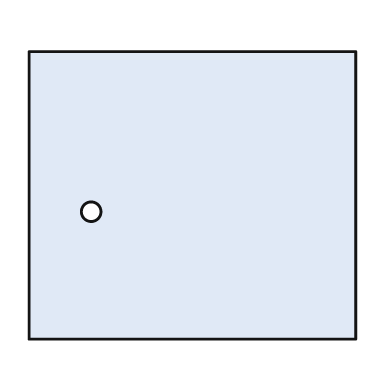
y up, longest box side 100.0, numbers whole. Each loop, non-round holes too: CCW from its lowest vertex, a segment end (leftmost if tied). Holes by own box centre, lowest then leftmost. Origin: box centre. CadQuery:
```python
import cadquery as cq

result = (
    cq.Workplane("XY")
    .moveTo(-50.0, -44.0)
    .lineTo(50.0, -44.0)
    .lineTo(50.0, 44.0)
    .lineTo(-50.0, 44.0)
    .close()
    .moveTo(-31.0, -5.0)
    .circle(3.0)
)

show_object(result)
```